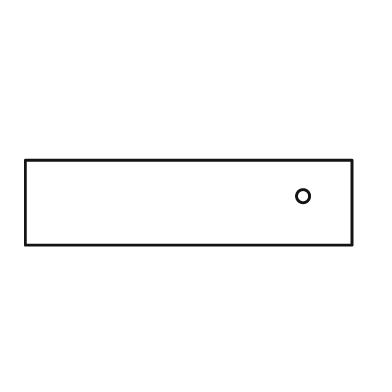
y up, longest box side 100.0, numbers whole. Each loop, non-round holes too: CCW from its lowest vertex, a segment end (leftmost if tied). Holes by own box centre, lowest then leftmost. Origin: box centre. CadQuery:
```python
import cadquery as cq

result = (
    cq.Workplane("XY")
    .moveTo(-50.0, -13.0)
    .lineTo(50.0, -13.0)
    .lineTo(50.0, 13.0)
    .lineTo(-50.0, 13.0)
    .close()
    .moveTo(35.0, 2.0)
    .circle(2.0)
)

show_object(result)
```